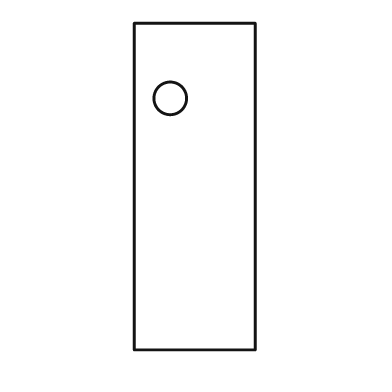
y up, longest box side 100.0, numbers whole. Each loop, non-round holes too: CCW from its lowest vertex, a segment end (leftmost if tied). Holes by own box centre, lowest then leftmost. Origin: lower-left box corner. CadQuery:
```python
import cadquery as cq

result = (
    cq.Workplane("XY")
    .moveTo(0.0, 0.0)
    .lineTo(37.0, 0.0)
    .lineTo(37.0, 100.0)
    .lineTo(0.0, 100.0)
    .close()
    .moveTo(11.0, 77.0)
    .circle(5.0)
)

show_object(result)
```